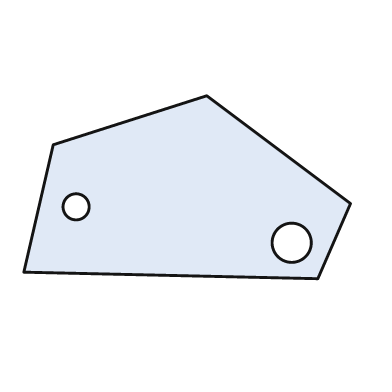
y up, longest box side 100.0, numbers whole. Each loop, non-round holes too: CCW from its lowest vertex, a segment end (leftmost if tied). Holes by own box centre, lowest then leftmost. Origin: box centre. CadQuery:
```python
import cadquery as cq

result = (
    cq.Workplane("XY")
    .moveTo(40.0, -28.0)
    .lineTo(50.0, -5.0)
    .lineTo(6.0, 28.0)
    .lineTo(-41.0, 13.0)
    .lineTo(-50.0, -26.0)
    .close()
    .moveTo(32.0, -17.0)
    .circle(6.0)
    .moveTo(-34.0, -6.0)
    .circle(4.0)
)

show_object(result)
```